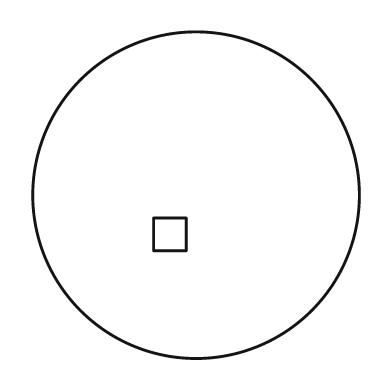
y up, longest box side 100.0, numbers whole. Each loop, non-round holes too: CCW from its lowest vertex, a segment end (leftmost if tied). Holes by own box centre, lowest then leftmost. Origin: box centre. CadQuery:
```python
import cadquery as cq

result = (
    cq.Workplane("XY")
    .moveTo(0.0, 0.0)
    .circle(50.0)
    .moveTo(-13.0, -17.0)
    .lineTo(-3.0, -17.0)
    .lineTo(-3.0, -7.0)
    .lineTo(-13.0, -7.0)
    .close()
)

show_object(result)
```